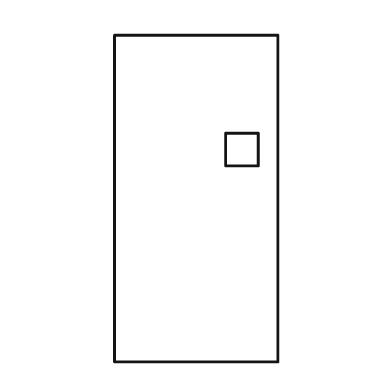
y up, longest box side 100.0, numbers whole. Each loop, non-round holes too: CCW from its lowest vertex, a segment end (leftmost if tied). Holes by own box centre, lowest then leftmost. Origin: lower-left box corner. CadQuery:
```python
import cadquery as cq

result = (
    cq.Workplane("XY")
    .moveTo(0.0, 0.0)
    .lineTo(50.0, 0.0)
    .lineTo(50.0, 100.0)
    .lineTo(0.0, 100.0)
    .close()
    .moveTo(34.0, 60.0)
    .lineTo(44.0, 60.0)
    .lineTo(44.0, 70.0)
    .lineTo(34.0, 70.0)
    .close()
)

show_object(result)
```